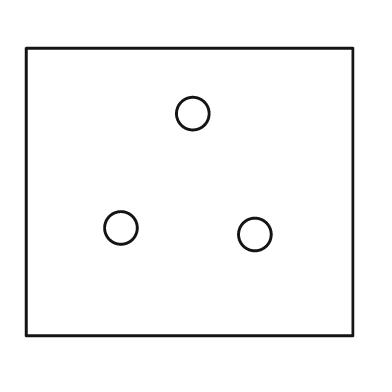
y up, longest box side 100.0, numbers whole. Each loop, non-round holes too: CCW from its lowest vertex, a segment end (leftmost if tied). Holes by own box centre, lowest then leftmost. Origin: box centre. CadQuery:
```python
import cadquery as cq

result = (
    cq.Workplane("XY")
    .moveTo(-50.0, -44.0)
    .lineTo(50.0, -44.0)
    .lineTo(50.0, 44.0)
    .lineTo(-50.0, 44.0)
    .close()
    .moveTo(20.0, -13.0)
    .circle(5.0)
    .moveTo(-21.0, -11.0)
    .circle(5.0)
    .moveTo(1.0, 24.0)
    .circle(5.0)
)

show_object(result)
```